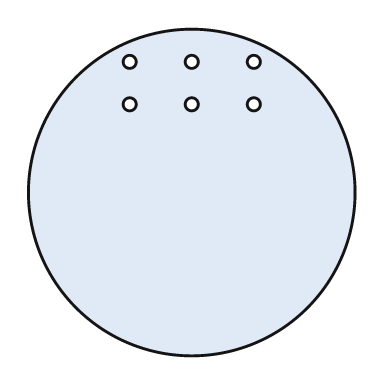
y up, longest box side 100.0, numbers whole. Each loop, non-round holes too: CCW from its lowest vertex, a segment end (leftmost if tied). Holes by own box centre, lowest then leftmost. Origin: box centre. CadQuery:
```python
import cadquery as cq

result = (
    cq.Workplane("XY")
    .moveTo(0.0, 0.0)
    .circle(50.0)
    .moveTo(-19.0, 27.0)
    .circle(2.0)
    .moveTo(0.0, 27.0)
    .circle(2.0)
    .moveTo(19.0, 27.0)
    .circle(2.0)
    .moveTo(-19.0, 40.0)
    .circle(2.0)
    .moveTo(0.0, 40.0)
    .circle(2.0)
    .moveTo(19.0, 40.0)
    .circle(2.0)
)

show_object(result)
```